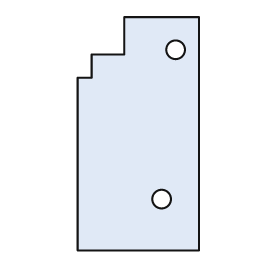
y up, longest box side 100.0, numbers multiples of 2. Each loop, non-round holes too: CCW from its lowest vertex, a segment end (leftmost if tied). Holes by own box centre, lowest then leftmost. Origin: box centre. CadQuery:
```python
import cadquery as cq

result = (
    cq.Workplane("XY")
    .moveTo(-26.0, -50.0)
    .lineTo(26.0, -50.0)
    .lineTo(26.0, 50.0)
    .lineTo(-6.0, 50.0)
    .lineTo(-6.0, 34.0)
    .lineTo(-20.0, 34.0)
    .lineTo(-20.0, 24.0)
    .lineTo(-26.0, 24.0)
    .close()
    .moveTo(10.0, -28.0)
    .circle(4.0)
    .moveTo(16.0, 36.0)
    .circle(4.0)
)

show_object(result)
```